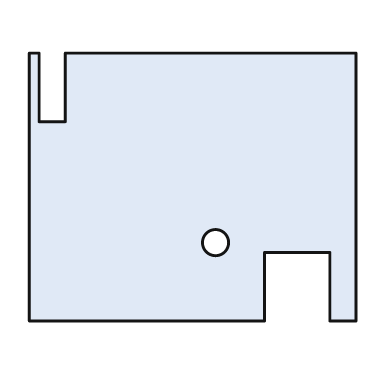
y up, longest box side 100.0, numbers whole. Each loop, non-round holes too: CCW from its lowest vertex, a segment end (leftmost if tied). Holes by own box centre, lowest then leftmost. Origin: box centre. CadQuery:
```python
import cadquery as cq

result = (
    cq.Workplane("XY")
    .moveTo(-50.0, -41.0)
    .lineTo(22.0, -41.0)
    .lineTo(22.0, -20.0)
    .lineTo(42.0, -20.0)
    .lineTo(42.0, -41.0)
    .lineTo(50.0, -41.0)
    .lineTo(50.0, 41.0)
    .lineTo(-39.0, 41.0)
    .lineTo(-39.0, 20.0)
    .lineTo(-47.0, 20.0)
    .lineTo(-47.0, 41.0)
    .lineTo(-50.0, 41.0)
    .close()
    .moveTo(7.0, -17.0)
    .circle(4.0)
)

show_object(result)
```